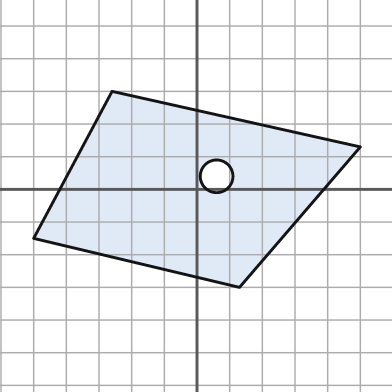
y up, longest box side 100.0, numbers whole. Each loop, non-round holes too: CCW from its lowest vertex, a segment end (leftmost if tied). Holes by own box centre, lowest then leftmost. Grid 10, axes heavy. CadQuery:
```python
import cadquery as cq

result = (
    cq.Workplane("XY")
    .moveTo(13.0, -30.0)
    .lineTo(50.0, 13.0)
    .lineTo(-26.0, 30.0)
    .lineTo(-50.0, -15.0)
    .close()
    .moveTo(6.0, 4.0)
    .circle(5.0)
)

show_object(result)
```